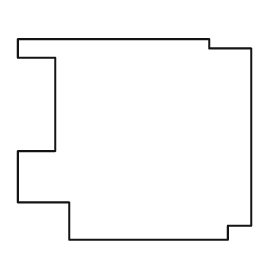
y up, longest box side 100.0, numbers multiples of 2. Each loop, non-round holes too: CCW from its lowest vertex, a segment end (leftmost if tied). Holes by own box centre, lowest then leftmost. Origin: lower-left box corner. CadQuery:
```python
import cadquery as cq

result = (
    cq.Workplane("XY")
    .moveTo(22.0, 0.0)
    .lineTo(90.0, 0.0)
    .lineTo(90.0, 6.0)
    .lineTo(100.0, 6.0)
    .lineTo(100.0, 82.0)
    .lineTo(82.0, 82.0)
    .lineTo(82.0, 86.0)
    .lineTo(0.0, 86.0)
    .lineTo(0.0, 78.0)
    .lineTo(16.0, 78.0)
    .lineTo(16.0, 38.0)
    .lineTo(0.0, 38.0)
    .lineTo(0.0, 16.0)
    .lineTo(22.0, 16.0)
    .close()
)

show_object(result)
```